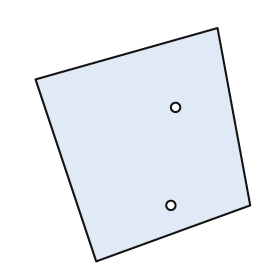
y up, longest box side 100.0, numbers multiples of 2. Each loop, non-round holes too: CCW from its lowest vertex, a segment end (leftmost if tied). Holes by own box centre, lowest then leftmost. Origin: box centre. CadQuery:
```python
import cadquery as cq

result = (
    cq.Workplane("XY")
    .moveTo(-20.0, -50.0)
    .lineTo(46.0, -26.0)
    .lineTo(32.0, 50.0)
    .lineTo(-46.0, 28.0)
    .close()
    .moveTo(12.0, -26.0)
    .circle(2.0)
    .moveTo(14.0, 16.0)
    .circle(2.0)
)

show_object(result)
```